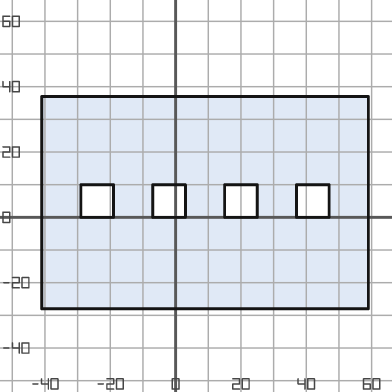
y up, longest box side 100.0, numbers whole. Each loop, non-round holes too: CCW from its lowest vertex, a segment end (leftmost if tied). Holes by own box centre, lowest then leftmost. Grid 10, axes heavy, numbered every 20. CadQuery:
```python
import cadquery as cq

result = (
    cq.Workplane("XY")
    .moveTo(-41.0, -28.0)
    .lineTo(59.0, -28.0)
    .lineTo(59.0, 37.0)
    .lineTo(-41.0, 37.0)
    .close()
    .moveTo(-29.0, 0.0)
    .lineTo(-19.0, 0.0)
    .lineTo(-19.0, 10.0)
    .lineTo(-29.0, 10.0)
    .close()
    .moveTo(-7.0, 0.0)
    .lineTo(3.0, 0.0)
    .lineTo(3.0, 10.0)
    .lineTo(-7.0, 10.0)
    .close()
    .moveTo(15.0, 0.0)
    .lineTo(25.0, 0.0)
    .lineTo(25.0, 10.0)
    .lineTo(15.0, 10.0)
    .close()
    .moveTo(37.0, 0.0)
    .lineTo(47.0, 0.0)
    .lineTo(47.0, 10.0)
    .lineTo(37.0, 10.0)
    .close()
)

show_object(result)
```